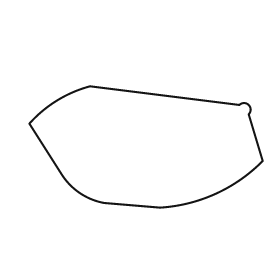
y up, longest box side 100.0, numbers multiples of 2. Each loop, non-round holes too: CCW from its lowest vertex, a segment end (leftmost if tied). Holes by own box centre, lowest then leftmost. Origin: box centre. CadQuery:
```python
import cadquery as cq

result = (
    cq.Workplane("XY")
    .moveTo(6.0, -26.0)
    .threePointArc((30.0, -20.0), (50.0, -6.0))
    .lineTo(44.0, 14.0)
    .threePointArc((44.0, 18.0), (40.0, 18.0))
    .lineTo(-24.0, 26.0)
    .threePointArc((-38.0, 20.0), (-50.0, 10.0))
    .lineTo(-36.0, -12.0)
    .threePointArc((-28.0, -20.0), (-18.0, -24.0))
    .close()
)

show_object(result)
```